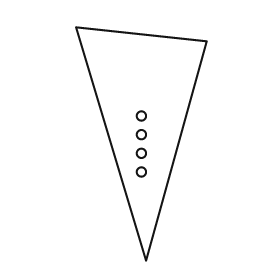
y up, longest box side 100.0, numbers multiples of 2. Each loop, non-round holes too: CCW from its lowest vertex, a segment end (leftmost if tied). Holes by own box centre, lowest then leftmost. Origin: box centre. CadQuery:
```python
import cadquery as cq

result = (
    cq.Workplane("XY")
    .moveTo(2.0, -50.0)
    .lineTo(28.0, 44.0)
    .lineTo(-28.0, 50.0)
    .close()
    .moveTo(0.0, -12.0)
    .circle(2.0)
    .moveTo(0.0, -4.0)
    .circle(2.0)
    .moveTo(0.0, 4.0)
    .circle(2.0)
    .moveTo(0.0, 12.0)
    .circle(2.0)
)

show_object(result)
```